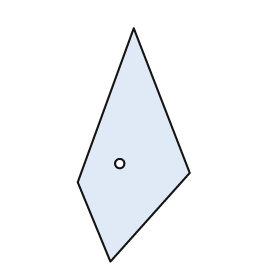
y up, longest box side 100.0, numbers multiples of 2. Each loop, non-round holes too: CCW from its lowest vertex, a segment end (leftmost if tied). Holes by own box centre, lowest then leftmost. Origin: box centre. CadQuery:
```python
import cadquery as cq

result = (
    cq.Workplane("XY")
    .moveTo(-10.0, -50.0)
    .lineTo(24.0, -12.0)
    .lineTo(0.0, 50.0)
    .lineTo(-24.0, -16.0)
    .close()
    .moveTo(-6.0, -8.0)
    .circle(2.0)
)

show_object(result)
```